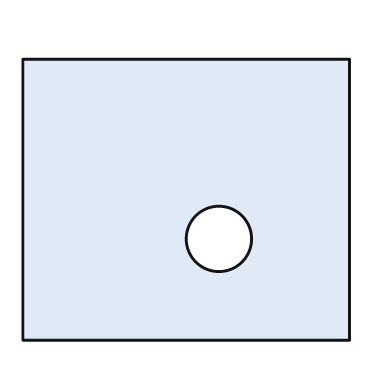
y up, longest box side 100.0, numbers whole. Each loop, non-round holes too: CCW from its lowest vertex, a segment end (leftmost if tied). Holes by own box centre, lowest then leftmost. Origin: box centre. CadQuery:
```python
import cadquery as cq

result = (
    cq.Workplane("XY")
    .moveTo(-50.0, -43.0)
    .lineTo(50.0, -43.0)
    .lineTo(50.0, 43.0)
    .lineTo(-50.0, 43.0)
    .close()
    .moveTo(10.0, -12.0)
    .circle(10.0)
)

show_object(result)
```